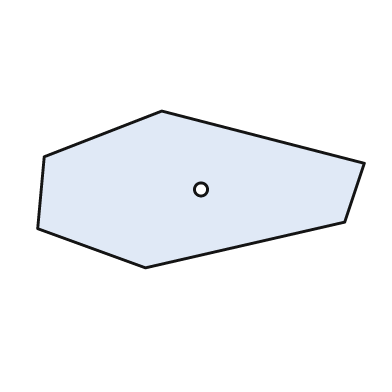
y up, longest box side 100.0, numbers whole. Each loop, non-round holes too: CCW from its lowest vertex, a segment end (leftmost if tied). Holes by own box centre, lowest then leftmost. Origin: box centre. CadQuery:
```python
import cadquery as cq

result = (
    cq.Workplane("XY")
    .moveTo(-17.0, -24.0)
    .lineTo(44.0, -10.0)
    .lineTo(50.0, 8.0)
    .lineTo(-12.0, 24.0)
    .lineTo(-48.0, 10.0)
    .lineTo(-50.0, -12.0)
    .close()
    .moveTo(0.0, 0.0)
    .circle(2.0)
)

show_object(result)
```